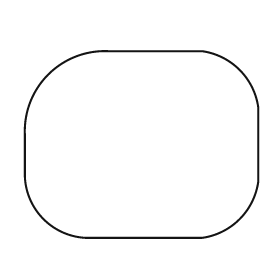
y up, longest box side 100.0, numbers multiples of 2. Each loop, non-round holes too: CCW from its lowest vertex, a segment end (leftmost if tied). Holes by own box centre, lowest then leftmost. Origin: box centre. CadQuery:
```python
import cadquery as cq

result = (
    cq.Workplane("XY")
    .moveTo(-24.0, -40.0)
    .lineTo(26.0, -40.0)
    .threePointArc((42.0, -32.0), (50.0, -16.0))
    .lineTo(50.0, 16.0)
    .threePointArc((42.0, 32.0), (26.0, 40.0))
    .lineTo(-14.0, 40.0)
    .threePointArc((-40.0, 30.0), (-50.0, 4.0))
    .lineTo(-50.0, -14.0)
    .threePointArc((-42.0, -32.0), (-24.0, -40.0))
    .close()
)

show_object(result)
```